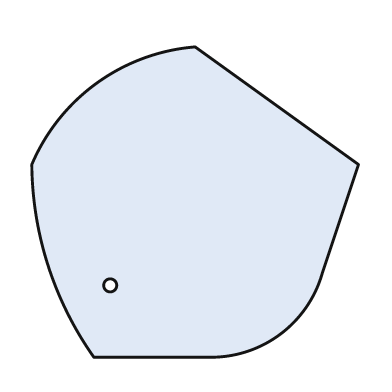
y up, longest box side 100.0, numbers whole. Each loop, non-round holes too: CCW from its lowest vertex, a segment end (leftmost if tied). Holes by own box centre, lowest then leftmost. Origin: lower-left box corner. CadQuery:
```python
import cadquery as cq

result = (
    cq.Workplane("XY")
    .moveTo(19.0, 0.0)
    .lineTo(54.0, 0.0)
    .threePointArc((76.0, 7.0), (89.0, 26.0))
    .lineTo(100.0, 59.0)
    .lineTo(50.0, 95.0)
    .threePointArc((20.0, 84.0), (0.0, 59.0))
    .threePointArc((5.0, 28.0), (19.0, 0.0))
    .close()
    .moveTo(24.0, 22.0)
    .circle(2.0)
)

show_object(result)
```